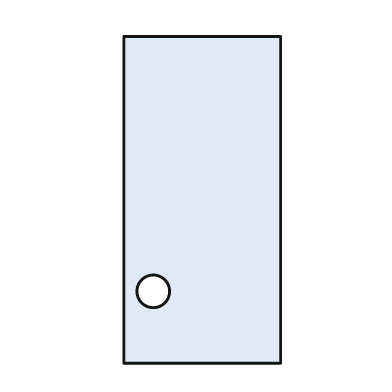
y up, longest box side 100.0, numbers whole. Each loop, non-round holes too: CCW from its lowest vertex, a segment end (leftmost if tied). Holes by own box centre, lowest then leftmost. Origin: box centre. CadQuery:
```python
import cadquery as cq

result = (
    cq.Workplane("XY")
    .moveTo(-24.0, -50.0)
    .lineTo(24.0, -50.0)
    .lineTo(24.0, 50.0)
    .lineTo(-24.0, 50.0)
    .close()
    .moveTo(-15.0, -28.0)
    .circle(5.0)
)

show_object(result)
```